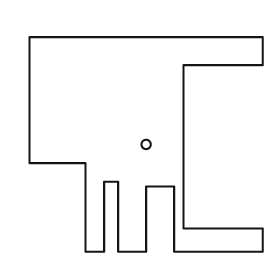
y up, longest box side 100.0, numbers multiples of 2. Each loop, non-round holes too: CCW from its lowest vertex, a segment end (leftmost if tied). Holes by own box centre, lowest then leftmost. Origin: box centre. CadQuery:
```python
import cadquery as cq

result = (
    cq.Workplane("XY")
    .moveTo(-26.0, -46.0)
    .lineTo(-18.0, -46.0)
    .lineTo(-18.0, -16.0)
    .lineTo(-12.0, -16.0)
    .lineTo(-12.0, -46.0)
    .lineTo(0.0, -46.0)
    .lineTo(0.0, -18.0)
    .lineTo(12.0, -18.0)
    .lineTo(12.0, -46.0)
    .lineTo(50.0, -46.0)
    .lineTo(50.0, -36.0)
    .lineTo(16.0, -36.0)
    .lineTo(16.0, 34.0)
    .lineTo(50.0, 34.0)
    .lineTo(50.0, 46.0)
    .lineTo(-50.0, 46.0)
    .lineTo(-50.0, -8.0)
    .lineTo(-26.0, -8.0)
    .close()
    .moveTo(0.0, 0.0)
    .circle(2.0)
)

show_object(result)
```